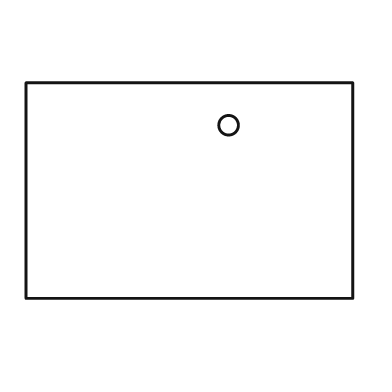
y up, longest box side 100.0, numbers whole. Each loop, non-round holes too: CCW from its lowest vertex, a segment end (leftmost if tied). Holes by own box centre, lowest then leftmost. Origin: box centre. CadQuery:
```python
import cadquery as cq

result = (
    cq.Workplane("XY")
    .moveTo(-50.0, -33.0)
    .lineTo(50.0, -33.0)
    .lineTo(50.0, 33.0)
    .lineTo(-50.0, 33.0)
    .close()
    .moveTo(12.0, 20.0)
    .circle(3.0)
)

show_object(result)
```